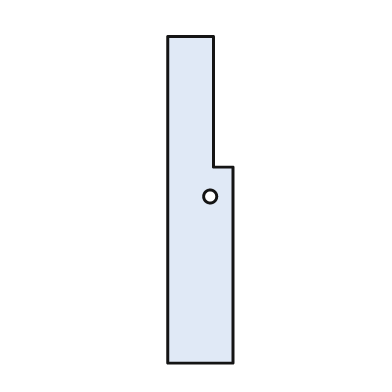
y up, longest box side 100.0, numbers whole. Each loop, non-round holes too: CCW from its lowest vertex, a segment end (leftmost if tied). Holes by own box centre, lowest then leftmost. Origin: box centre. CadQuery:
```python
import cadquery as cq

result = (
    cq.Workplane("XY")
    .moveTo(-10.0, -50.0)
    .lineTo(10.0, -50.0)
    .lineTo(10.0, 10.0)
    .lineTo(4.0, 10.0)
    .lineTo(4.0, 50.0)
    .lineTo(-10.0, 50.0)
    .close()
    .moveTo(3.0, 1.0)
    .circle(2.0)
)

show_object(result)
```